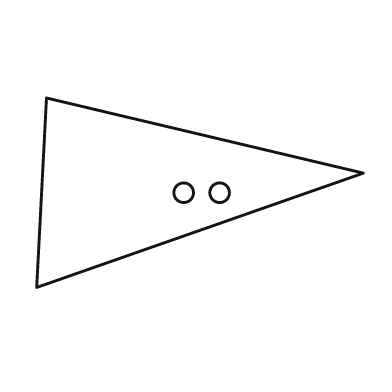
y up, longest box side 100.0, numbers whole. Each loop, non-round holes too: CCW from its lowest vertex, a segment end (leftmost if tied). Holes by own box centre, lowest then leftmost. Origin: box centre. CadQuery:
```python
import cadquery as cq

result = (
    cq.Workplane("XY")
    .moveTo(-50.0, -29.0)
    .lineTo(50.0, 6.0)
    .lineTo(-47.0, 29.0)
    .close()
    .moveTo(-5.0, 0.0)
    .circle(3.0)
    .moveTo(6.0, 0.0)
    .circle(3.0)
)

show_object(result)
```